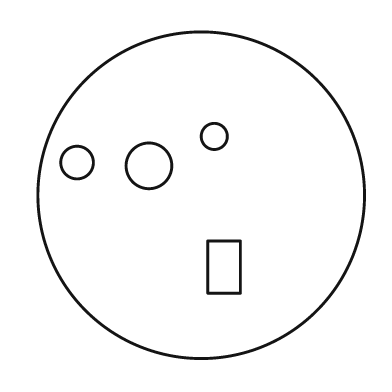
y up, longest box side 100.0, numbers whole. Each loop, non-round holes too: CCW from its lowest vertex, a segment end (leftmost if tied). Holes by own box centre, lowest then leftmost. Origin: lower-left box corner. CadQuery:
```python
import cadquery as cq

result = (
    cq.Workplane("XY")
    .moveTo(50.0, 50.0)
    .circle(50.0)
    .moveTo(52.0, 20.0)
    .lineTo(62.0, 20.0)
    .lineTo(62.0, 36.0)
    .lineTo(52.0, 36.0)
    .close()
    .moveTo(34.0, 59.0)
    .circle(7.0)
    .moveTo(12.0, 60.0)
    .circle(5.0)
    .moveTo(54.0, 68.0)
    .circle(4.0)
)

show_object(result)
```